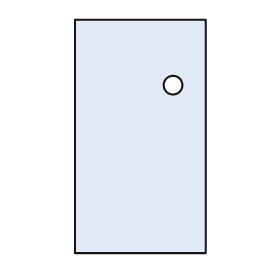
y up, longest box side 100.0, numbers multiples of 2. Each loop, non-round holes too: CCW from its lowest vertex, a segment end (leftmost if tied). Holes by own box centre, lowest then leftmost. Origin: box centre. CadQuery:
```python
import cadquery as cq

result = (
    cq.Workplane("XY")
    .moveTo(-28.0, -50.0)
    .lineTo(28.0, -50.0)
    .lineTo(28.0, 50.0)
    .lineTo(-28.0, 50.0)
    .close()
    .moveTo(14.0, 22.0)
    .circle(4.0)
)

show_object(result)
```